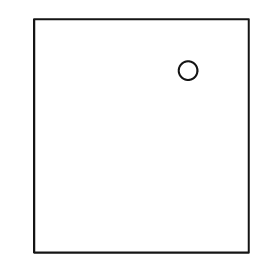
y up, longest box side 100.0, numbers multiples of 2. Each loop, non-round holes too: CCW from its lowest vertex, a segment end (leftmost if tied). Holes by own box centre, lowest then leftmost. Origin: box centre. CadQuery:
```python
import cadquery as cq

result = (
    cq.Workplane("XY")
    .moveTo(-46.0, -50.0)
    .lineTo(46.0, -50.0)
    .lineTo(46.0, 50.0)
    .lineTo(-46.0, 50.0)
    .close()
    .moveTo(20.0, 28.0)
    .circle(4.0)
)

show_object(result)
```